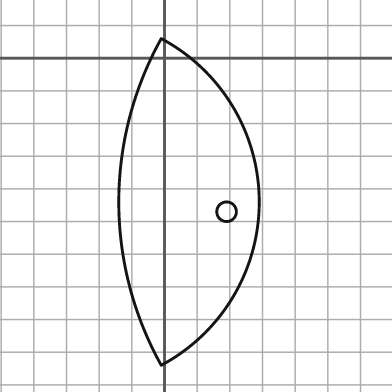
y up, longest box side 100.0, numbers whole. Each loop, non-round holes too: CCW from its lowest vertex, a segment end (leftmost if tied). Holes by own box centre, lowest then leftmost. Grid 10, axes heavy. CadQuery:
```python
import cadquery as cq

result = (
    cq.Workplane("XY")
    .moveTo(-1.0, -94.0)
    .threePointArc((29.0, -44.0), (-1.0, 6.0))
    .threePointArc((-14.0, -44.0), (-1.0, -94.0))
    .close()
    .moveTo(19.0, -47.0)
    .circle(3.0)
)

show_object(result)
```